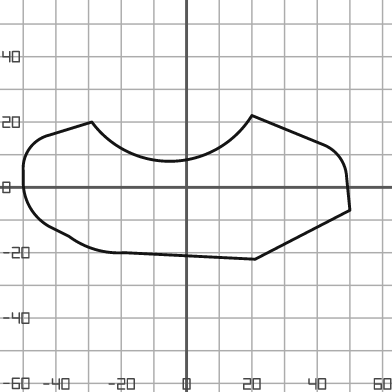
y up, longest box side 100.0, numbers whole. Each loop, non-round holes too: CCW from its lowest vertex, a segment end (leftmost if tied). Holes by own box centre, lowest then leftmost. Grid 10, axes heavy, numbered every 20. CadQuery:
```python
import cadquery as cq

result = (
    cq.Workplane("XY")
    .moveTo(21.0, -22.0)
    .lineTo(50.0, -7.0)
    .lineTo(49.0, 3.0)
    .threePointArc((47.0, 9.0), (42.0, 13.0))
    .lineTo(20.0, 22.0)
    .threePointArc((-4.0, 8.0), (-29.0, 20.0))
    .lineTo(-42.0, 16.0)
    .threePointArc((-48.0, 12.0), (-50.0, 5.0))
    .lineTo(-50.0, 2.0)
    .threePointArc((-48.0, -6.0), (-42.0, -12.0))
    .lineTo(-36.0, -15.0)
    .threePointArc((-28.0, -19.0), (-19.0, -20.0))
    .close()
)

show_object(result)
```